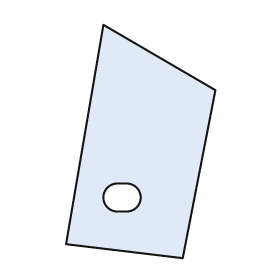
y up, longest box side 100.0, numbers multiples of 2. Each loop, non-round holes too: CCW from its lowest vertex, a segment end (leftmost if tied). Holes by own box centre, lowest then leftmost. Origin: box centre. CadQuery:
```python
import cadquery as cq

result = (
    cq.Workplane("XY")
    .moveTo(18.0, -50.0)
    .lineTo(32.0, 22.0)
    .lineTo(-16.0, 50.0)
    .lineTo(-32.0, -44.0)
    .close()
    .moveTo(-10.0, -30.0)
    .lineTo(-6.0, -30.0)
    .threePointArc((0.0, -24.0), (-6.0, -18.0))
    .lineTo(-10.0, -18.0)
    .threePointArc((-16.0, -24.0), (-10.0, -30.0))
    .close()
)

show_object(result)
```